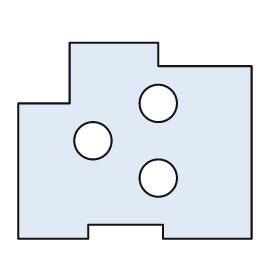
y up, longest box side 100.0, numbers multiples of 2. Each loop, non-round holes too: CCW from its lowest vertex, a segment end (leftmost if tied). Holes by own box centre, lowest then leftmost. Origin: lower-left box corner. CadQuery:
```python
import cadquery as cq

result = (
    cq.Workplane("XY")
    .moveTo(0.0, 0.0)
    .lineTo(30.0, 0.0)
    .lineTo(30.0, 6.0)
    .lineTo(62.0, 6.0)
    .lineTo(62.0, 0.0)
    .lineTo(100.0, 0.0)
    .lineTo(100.0, 74.0)
    .lineTo(60.0, 74.0)
    .lineTo(60.0, 84.0)
    .lineTo(22.0, 84.0)
    .lineTo(22.0, 58.0)
    .lineTo(0.0, 58.0)
    .close()
    .moveTo(60.0, 26.0)
    .circle(8.0)
    .moveTo(32.0, 42.0)
    .circle(8.0)
    .moveTo(60.0, 58.0)
    .circle(8.0)
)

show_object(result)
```